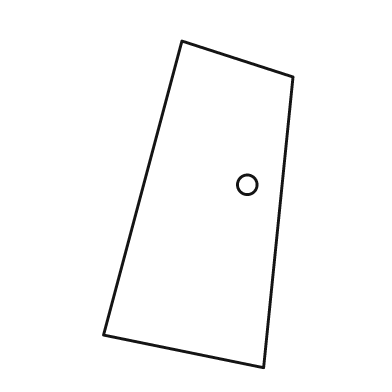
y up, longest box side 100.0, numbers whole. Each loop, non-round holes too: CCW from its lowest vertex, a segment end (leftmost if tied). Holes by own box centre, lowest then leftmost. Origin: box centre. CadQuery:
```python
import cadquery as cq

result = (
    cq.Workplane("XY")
    .moveTo(20.0, -50.0)
    .lineTo(29.0, 39.0)
    .lineTo(-5.0, 50.0)
    .lineTo(-29.0, -40.0)
    .close()
    .moveTo(15.0, 6.0)
    .circle(3.0)
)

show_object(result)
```